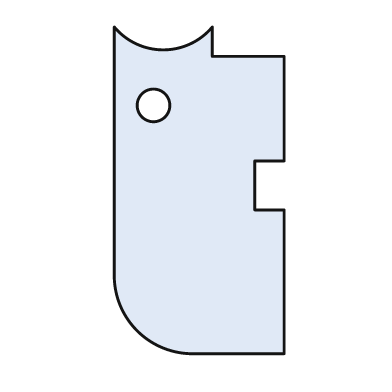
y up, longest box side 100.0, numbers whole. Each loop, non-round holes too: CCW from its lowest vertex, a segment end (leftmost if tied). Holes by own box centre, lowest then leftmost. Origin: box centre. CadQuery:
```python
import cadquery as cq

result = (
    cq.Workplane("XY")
    .moveTo(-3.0, -50.0)
    .lineTo(26.0, -50.0)
    .lineTo(26.0, -6.0)
    .lineTo(17.0, -6.0)
    .lineTo(17.0, 9.0)
    .lineTo(26.0, 9.0)
    .lineTo(26.0, 41.0)
    .lineTo(4.0, 41.0)
    .lineTo(4.0, 50.0)
    .threePointArc((-11.0, 43.0), (-26.0, 50.0))
    .lineTo(-26.0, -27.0)
    .threePointArc((-19.0, -43.0), (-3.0, -50.0))
    .close()
    .moveTo(-14.0, 26.0)
    .circle(5.0)
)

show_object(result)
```